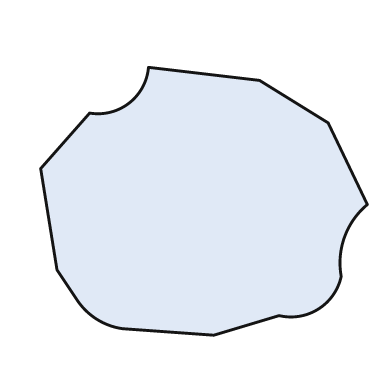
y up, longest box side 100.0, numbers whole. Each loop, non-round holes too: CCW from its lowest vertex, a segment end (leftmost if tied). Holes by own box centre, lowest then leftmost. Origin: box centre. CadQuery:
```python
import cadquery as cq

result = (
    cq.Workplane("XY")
    .moveTo(3.0, -41.0)
    .lineTo(23.0, -35.0)
    .threePointArc((35.0, -33.0), (42.0, -23.0))
    .threePointArc((43.0, -11.0), (50.0, -1.0))
    .lineTo(38.0, 24.0)
    .lineTo(17.0, 37.0)
    .lineTo(-17.0, 41.0)
    .threePointArc((-23.0, 30.0), (-35.0, 27.0))
    .lineTo(-50.0, 10.0)
    .lineTo(-45.0, -21.0)
    .lineTo(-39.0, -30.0)
    .threePointArc((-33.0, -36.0), (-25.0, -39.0))
    .close()
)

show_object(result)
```